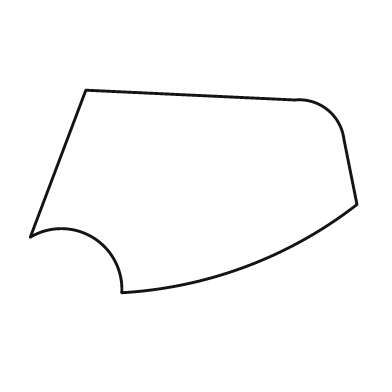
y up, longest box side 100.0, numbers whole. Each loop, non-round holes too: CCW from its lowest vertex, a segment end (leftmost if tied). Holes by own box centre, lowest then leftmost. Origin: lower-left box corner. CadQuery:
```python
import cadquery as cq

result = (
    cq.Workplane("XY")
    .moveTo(28.0, 0.0)
    .threePointArc((66.0, 8.0), (100.0, 27.0))
    .lineTo(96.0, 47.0)
    .threePointArc((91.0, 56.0), (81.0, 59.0))
    .lineTo(17.0, 62.0)
    .lineTo(0.0, 17.0)
    .threePointArc((19.0, 17.0), (28.0, 0.0))
    .close()
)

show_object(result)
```